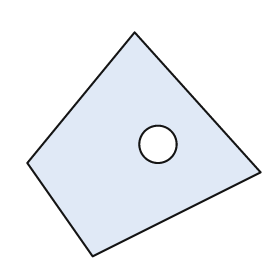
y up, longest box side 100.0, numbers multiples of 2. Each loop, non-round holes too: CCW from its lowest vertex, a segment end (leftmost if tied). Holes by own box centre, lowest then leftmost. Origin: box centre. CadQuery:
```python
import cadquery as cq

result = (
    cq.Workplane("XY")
    .moveTo(-22.0, -48.0)
    .lineTo(50.0, -12.0)
    .lineTo(-4.0, 48.0)
    .lineTo(-50.0, -8.0)
    .close()
    .moveTo(6.0, 0.0)
    .circle(8.0)
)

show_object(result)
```